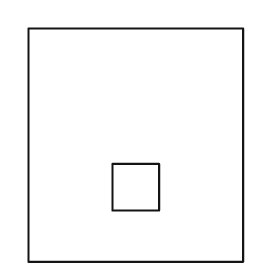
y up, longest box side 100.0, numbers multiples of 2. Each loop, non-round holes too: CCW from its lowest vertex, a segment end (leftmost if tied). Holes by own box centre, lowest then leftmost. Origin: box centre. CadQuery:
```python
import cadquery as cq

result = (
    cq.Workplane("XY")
    .moveTo(-46.0, -50.0)
    .lineTo(46.0, -50.0)
    .lineTo(46.0, 50.0)
    .lineTo(-46.0, 50.0)
    .close()
    .moveTo(-10.0, -28.0)
    .lineTo(10.0, -28.0)
    .lineTo(10.0, -8.0)
    .lineTo(-10.0, -8.0)
    .close()
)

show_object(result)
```